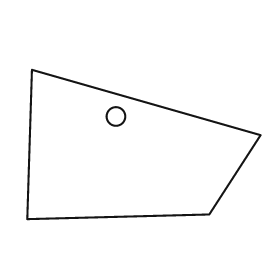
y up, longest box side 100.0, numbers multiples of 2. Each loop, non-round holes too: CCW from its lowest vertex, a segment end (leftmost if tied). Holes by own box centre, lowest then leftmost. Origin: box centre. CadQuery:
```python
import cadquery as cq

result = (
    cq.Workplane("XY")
    .moveTo(-50.0, -32.0)
    .lineTo(28.0, -30.0)
    .lineTo(50.0, 4.0)
    .lineTo(-48.0, 32.0)
    .close()
    .moveTo(-12.0, 12.0)
    .circle(4.0)
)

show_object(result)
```